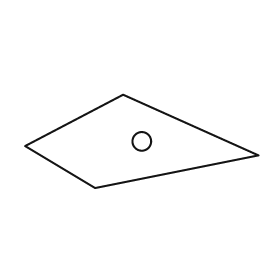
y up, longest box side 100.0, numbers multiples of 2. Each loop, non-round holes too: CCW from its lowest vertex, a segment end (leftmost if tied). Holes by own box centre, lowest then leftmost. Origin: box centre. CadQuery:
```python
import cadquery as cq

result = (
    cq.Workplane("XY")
    .moveTo(-20.0, -20.0)
    .lineTo(50.0, -6.0)
    .lineTo(-8.0, 20.0)
    .lineTo(-50.0, -2.0)
    .close()
    .moveTo(0.0, 0.0)
    .circle(4.0)
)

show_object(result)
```